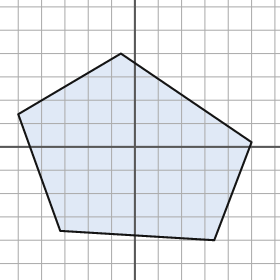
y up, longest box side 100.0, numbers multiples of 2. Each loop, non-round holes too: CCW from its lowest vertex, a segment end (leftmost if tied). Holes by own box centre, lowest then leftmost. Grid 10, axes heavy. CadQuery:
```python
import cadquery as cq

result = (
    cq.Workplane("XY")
    .moveTo(34.0, -40.0)
    .lineTo(50.0, 2.0)
    .lineTo(-6.0, 40.0)
    .lineTo(-50.0, 14.0)
    .lineTo(-32.0, -36.0)
    .close()
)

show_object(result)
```